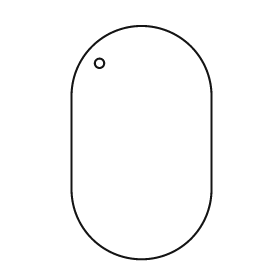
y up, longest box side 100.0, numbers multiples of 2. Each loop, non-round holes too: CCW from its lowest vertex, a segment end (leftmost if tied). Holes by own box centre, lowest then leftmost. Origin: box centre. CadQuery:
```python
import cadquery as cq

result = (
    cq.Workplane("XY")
    .moveTo(-30.0, -20.0)
    .threePointArc((0.0, -50.0), (30.0, -20.0))
    .lineTo(30.0, 20.0)
    .threePointArc((0.0, 50.0), (-30.0, 20.0))
    .close()
    .moveTo(-18.0, 34.0)
    .circle(2.0)
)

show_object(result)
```